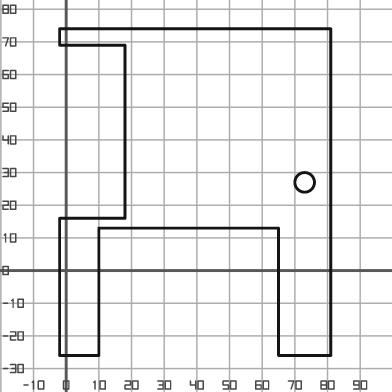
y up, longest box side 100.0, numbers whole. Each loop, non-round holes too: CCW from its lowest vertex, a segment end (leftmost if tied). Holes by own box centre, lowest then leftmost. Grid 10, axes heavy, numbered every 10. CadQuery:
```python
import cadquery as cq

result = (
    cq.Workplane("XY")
    .moveTo(-2.0, -26.0)
    .lineTo(10.0, -26.0)
    .lineTo(10.0, 13.0)
    .lineTo(65.0, 13.0)
    .lineTo(65.0, -26.0)
    .lineTo(81.0, -26.0)
    .lineTo(81.0, 74.0)
    .lineTo(-2.0, 74.0)
    .lineTo(-2.0, 69.0)
    .lineTo(18.0, 69.0)
    .lineTo(18.0, 16.0)
    .lineTo(-2.0, 16.0)
    .close()
    .moveTo(73.0, 27.0)
    .circle(3.0)
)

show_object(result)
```